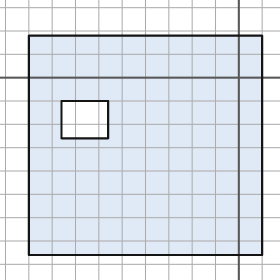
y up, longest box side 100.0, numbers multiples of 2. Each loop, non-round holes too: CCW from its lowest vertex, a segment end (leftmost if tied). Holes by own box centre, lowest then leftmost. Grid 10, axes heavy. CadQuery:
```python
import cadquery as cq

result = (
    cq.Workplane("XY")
    .moveTo(-90.0, -76.0)
    .lineTo(10.0, -76.0)
    .lineTo(10.0, 18.0)
    .lineTo(-90.0, 18.0)
    .close()
    .moveTo(-76.0, -26.0)
    .lineTo(-56.0, -26.0)
    .lineTo(-56.0, -10.0)
    .lineTo(-76.0, -10.0)
    .close()
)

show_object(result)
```